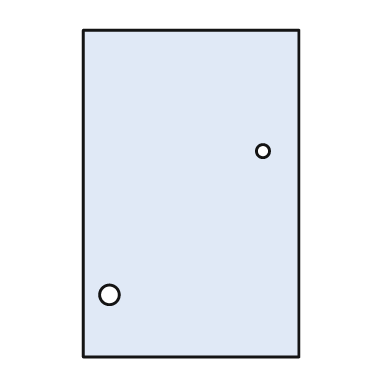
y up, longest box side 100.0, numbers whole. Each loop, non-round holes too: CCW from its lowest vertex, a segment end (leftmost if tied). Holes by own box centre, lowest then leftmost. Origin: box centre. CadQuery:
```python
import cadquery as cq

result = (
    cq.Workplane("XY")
    .moveTo(-33.0, -50.0)
    .lineTo(33.0, -50.0)
    .lineTo(33.0, 50.0)
    .lineTo(-33.0, 50.0)
    .close()
    .moveTo(-25.0, -31.0)
    .circle(3.0)
    .moveTo(22.0, 13.0)
    .circle(2.0)
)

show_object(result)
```